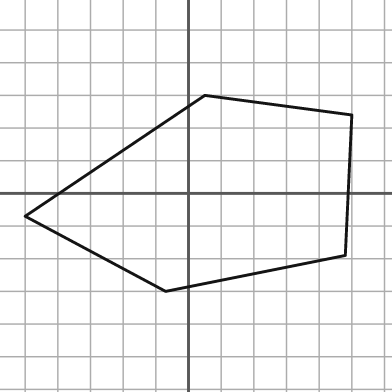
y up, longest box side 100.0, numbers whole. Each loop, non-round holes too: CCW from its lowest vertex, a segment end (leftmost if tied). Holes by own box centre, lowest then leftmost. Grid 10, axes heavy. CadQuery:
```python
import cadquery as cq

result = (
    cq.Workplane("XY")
    .moveTo(-7.0, -30.0)
    .lineTo(48.0, -19.0)
    .lineTo(50.0, 24.0)
    .lineTo(5.0, 30.0)
    .lineTo(-50.0, -7.0)
    .close()
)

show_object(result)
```